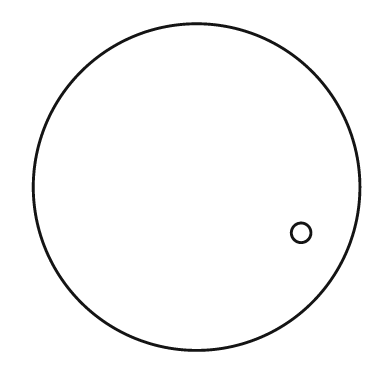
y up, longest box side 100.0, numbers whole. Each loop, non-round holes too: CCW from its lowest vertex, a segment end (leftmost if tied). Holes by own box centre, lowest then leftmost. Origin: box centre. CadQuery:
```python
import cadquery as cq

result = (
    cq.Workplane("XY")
    .moveTo(0.0, 0.0)
    .circle(50.0)
    .moveTo(32.0, -14.0)
    .circle(3.0)
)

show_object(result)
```